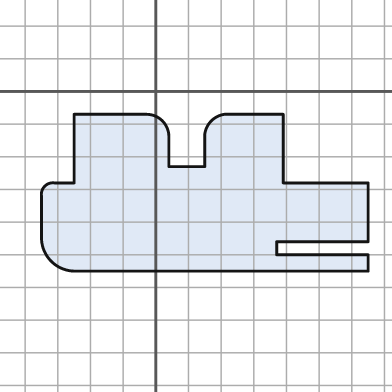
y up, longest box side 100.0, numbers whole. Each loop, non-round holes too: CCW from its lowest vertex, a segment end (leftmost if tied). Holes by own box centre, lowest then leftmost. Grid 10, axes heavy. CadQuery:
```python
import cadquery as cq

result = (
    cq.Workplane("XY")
    .moveTo(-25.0, -55.0)
    .lineTo(65.0, -55.0)
    .lineTo(65.0, -50.0)
    .lineTo(37.0, -50.0)
    .lineTo(37.0, -46.0)
    .lineTo(65.0, -46.0)
    .lineTo(65.0, -28.0)
    .lineTo(39.0, -28.0)
    .lineTo(39.0, -7.0)
    .lineTo(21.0, -7.0)
    .threePointArc((17.0, -9.0), (15.0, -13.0))
    .lineTo(15.0, -23.0)
    .lineTo(4.0, -23.0)
    .lineTo(4.0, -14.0)
    .threePointArc((2.0, -9.0), (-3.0, -7.0))
    .lineTo(-25.0, -7.0)
    .lineTo(-25.0, -28.0)
    .lineTo(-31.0, -28.0)
    .threePointArc((-34.0, -29.0), (-35.0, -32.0))
    .lineTo(-35.0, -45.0)
    .threePointArc((-32.0, -52.0), (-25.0, -55.0))
    .close()
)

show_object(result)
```